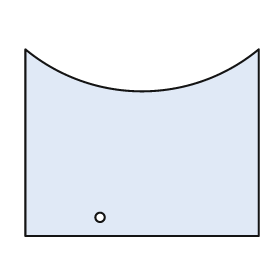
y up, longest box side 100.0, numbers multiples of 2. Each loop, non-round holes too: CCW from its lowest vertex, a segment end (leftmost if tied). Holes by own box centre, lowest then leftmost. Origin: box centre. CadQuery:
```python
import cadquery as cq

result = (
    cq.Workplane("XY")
    .moveTo(-50.0, -40.0)
    .lineTo(50.0, -40.0)
    .lineTo(50.0, 40.0)
    .threePointArc((0.0, 22.0), (-50.0, 40.0))
    .close()
    .moveTo(-18.0, -32.0)
    .circle(2.0)
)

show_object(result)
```